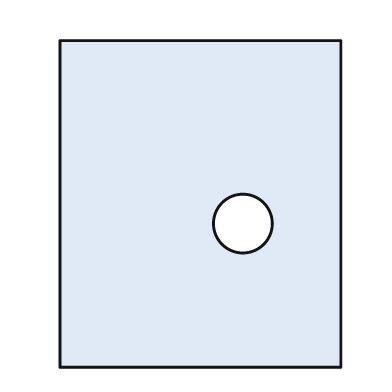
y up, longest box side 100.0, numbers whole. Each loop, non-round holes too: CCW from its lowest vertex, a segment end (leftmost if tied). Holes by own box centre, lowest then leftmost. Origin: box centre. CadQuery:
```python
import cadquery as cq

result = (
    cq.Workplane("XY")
    .moveTo(-43.0, -50.0)
    .lineTo(43.0, -50.0)
    .lineTo(43.0, 50.0)
    .lineTo(-43.0, 50.0)
    .close()
    .moveTo(13.0, -6.0)
    .circle(9.0)
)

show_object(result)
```